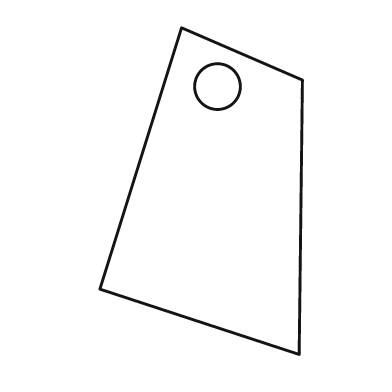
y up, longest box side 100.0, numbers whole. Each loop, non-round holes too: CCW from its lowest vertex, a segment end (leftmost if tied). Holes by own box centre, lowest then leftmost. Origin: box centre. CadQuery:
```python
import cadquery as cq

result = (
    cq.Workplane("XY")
    .moveTo(30.0, -50.0)
    .lineTo(31.0, 34.0)
    .lineTo(-6.0, 50.0)
    .lineTo(-31.0, -30.0)
    .close()
    .moveTo(5.0, 32.0)
    .circle(7.0)
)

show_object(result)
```